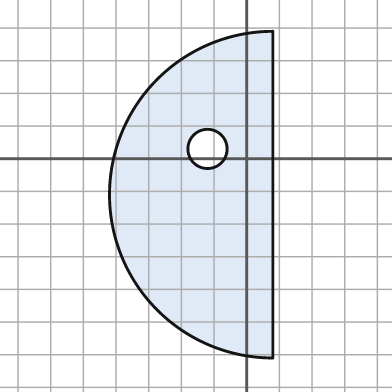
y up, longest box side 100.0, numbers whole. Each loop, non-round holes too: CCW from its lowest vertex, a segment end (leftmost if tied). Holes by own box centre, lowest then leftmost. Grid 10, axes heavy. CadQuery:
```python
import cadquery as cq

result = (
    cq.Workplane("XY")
    .moveTo(8.0, -61.0)
    .lineTo(8.0, 39.0)
    .threePointArc((-42.0, -11.0), (8.0, -61.0))
    .close()
    .moveTo(-12.0, 3.0)
    .circle(6.0)
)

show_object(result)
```